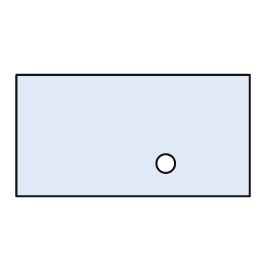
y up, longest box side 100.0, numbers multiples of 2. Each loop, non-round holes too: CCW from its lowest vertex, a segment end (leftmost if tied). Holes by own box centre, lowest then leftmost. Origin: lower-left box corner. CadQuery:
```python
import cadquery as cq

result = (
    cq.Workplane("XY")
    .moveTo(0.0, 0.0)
    .lineTo(100.0, 0.0)
    .lineTo(100.0, 52.0)
    .lineTo(0.0, 52.0)
    .close()
    .moveTo(64.0, 14.0)
    .circle(4.0)
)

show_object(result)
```